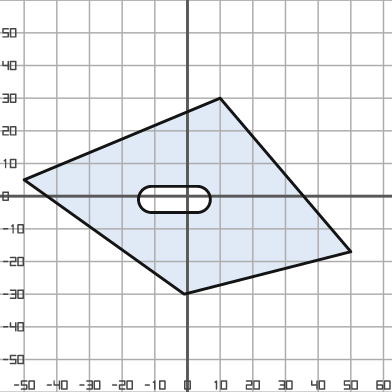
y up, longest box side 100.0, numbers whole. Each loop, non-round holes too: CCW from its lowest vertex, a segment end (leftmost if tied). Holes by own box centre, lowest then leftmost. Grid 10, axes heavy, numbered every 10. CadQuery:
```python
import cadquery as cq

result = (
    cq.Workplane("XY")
    .moveTo(-1.0, -30.0)
    .lineTo(50.0, -17.0)
    .lineTo(10.0, 30.0)
    .lineTo(-50.0, 5.0)
    .close()
    .moveTo(-11.0, -5.0)
    .lineTo(3.0, -5.0)
    .threePointArc((7.0, -1.0), (3.0, 3.0))
    .lineTo(-11.0, 3.0)
    .threePointArc((-15.0, -1.0), (-11.0, -5.0))
    .close()
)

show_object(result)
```